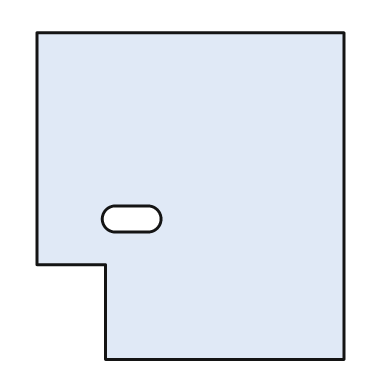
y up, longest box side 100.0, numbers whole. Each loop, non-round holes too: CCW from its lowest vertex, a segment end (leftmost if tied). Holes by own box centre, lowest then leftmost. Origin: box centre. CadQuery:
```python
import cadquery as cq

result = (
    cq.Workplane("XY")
    .moveTo(-26.0, -50.0)
    .lineTo(47.0, -50.0)
    .lineTo(47.0, 50.0)
    .lineTo(-47.0, 50.0)
    .lineTo(-47.0, -21.0)
    .lineTo(-26.0, -21.0)
    .close()
    .moveTo(-23.0, -11.0)
    .lineTo(-13.0, -11.0)
    .threePointArc((-9.0, -7.0), (-13.0, -3.0))
    .lineTo(-23.0, -3.0)
    .threePointArc((-27.0, -7.0), (-23.0, -11.0))
    .close()
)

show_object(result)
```